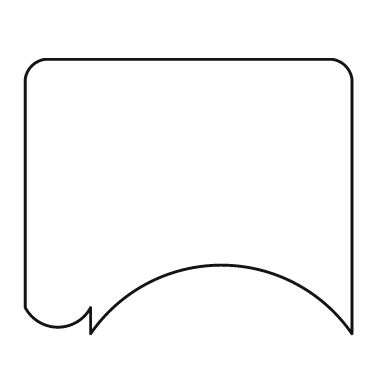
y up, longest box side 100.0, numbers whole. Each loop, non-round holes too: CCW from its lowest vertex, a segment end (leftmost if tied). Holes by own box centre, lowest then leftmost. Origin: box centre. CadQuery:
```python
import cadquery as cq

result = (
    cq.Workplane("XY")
    .moveTo(-30.0, -42.0)
    .threePointArc((10.0, -21.0), (50.0, -42.0))
    .lineTo(50.0, 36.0)
    .threePointArc((48.0, 40.0), (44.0, 42.0))
    .lineTo(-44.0, 42.0)
    .threePointArc((-48.0, 40.0), (-50.0, 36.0))
    .lineTo(-50.0, -34.0)
    .threePointArc((-40.0, -40.0), (-30.0, -34.0))
    .close()
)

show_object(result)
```